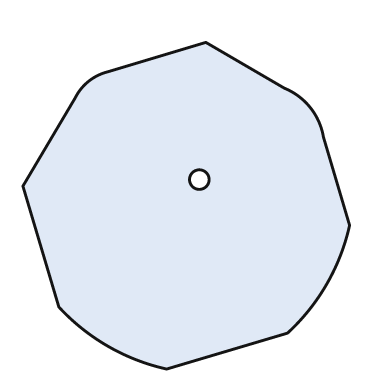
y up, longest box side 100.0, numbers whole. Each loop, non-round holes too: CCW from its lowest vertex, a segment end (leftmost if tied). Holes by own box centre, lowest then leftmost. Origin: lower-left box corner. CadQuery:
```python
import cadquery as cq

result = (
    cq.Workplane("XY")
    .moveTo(44.0, 0.0)
    .lineTo(81.0, 11.0)
    .threePointArc((93.0, 26.0), (100.0, 44.0))
    .lineTo(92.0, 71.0)
    .threePointArc((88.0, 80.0), (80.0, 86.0))
    .lineTo(56.0, 100.0)
    .lineTo(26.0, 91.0)
    .threePointArc((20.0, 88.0), (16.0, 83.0))
    .lineTo(0.0, 56.0)
    .lineTo(11.0, 19.0)
    .threePointArc((26.0, 7.0), (44.0, 0.0))
    .close()
    .moveTo(54.0, 58.0)
    .circle(3.0)
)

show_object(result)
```